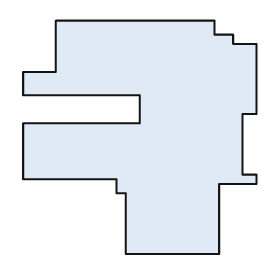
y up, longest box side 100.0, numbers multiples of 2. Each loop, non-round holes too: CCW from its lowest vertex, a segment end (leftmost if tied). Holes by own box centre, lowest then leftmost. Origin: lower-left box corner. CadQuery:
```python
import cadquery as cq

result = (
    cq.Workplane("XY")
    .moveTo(44.0, 0.0)
    .lineTo(84.0, 0.0)
    .lineTo(84.0, 30.0)
    .lineTo(100.0, 30.0)
    .lineTo(100.0, 34.0)
    .lineTo(94.0, 34.0)
    .lineTo(94.0, 60.0)
    .lineTo(100.0, 60.0)
    .lineTo(100.0, 90.0)
    .lineTo(90.0, 90.0)
    .lineTo(90.0, 94.0)
    .lineTo(82.0, 94.0)
    .lineTo(82.0, 100.0)
    .lineTo(14.0, 100.0)
    .lineTo(14.0, 78.0)
    .lineTo(0.0, 78.0)
    .lineTo(0.0, 68.0)
    .lineTo(50.0, 68.0)
    .lineTo(50.0, 56.0)
    .lineTo(0.0, 56.0)
    .lineTo(0.0, 32.0)
    .lineTo(40.0, 32.0)
    .lineTo(40.0, 26.0)
    .lineTo(44.0, 26.0)
    .close()
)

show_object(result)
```